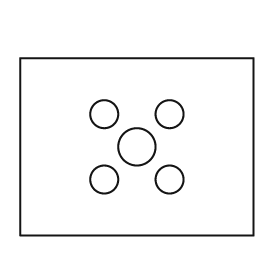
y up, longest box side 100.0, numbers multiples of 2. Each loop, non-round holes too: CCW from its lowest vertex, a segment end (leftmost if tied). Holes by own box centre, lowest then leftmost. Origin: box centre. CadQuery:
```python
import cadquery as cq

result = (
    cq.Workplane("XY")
    .moveTo(-50.0, -38.0)
    .lineTo(50.0, -38.0)
    .lineTo(50.0, 38.0)
    .lineTo(-50.0, 38.0)
    .close()
    .moveTo(-14.0, -14.0)
    .circle(6.0)
    .moveTo(14.0, -14.0)
    .circle(6.0)
    .moveTo(0.0, 0.0)
    .circle(8.0)
    .moveTo(-14.0, 14.0)
    .circle(6.0)
    .moveTo(14.0, 14.0)
    .circle(6.0)
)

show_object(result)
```